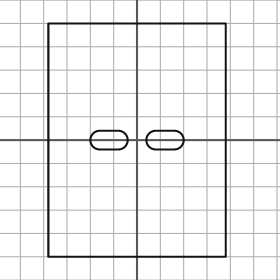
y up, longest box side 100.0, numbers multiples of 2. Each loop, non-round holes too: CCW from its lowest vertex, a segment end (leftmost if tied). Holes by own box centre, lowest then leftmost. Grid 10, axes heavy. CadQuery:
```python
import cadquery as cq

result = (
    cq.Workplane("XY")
    .moveTo(-38.0, -50.0)
    .lineTo(38.0, -50.0)
    .lineTo(38.0, 50.0)
    .lineTo(-38.0, 50.0)
    .close()
    .moveTo(-16.0, -4.0)
    .lineTo(-8.0, -4.0)
    .threePointArc((-4.0, 0.0), (-8.0, 4.0))
    .lineTo(-16.0, 4.0)
    .threePointArc((-20.0, 0.0), (-16.0, -4.0))
    .close()
    .moveTo(8.0, -4.0)
    .lineTo(16.0, -4.0)
    .threePointArc((20.0, 0.0), (16.0, 4.0))
    .lineTo(8.0, 4.0)
    .threePointArc((4.0, 0.0), (8.0, -4.0))
    .close()
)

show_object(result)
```